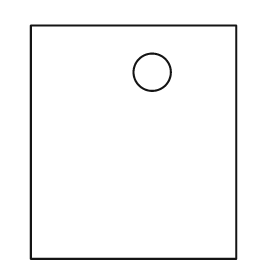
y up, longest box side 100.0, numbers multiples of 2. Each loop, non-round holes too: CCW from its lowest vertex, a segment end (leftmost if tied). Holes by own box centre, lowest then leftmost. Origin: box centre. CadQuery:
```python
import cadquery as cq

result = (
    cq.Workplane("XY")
    .moveTo(-44.0, -50.0)
    .lineTo(44.0, -50.0)
    .lineTo(44.0, 50.0)
    .lineTo(-44.0, 50.0)
    .close()
    .moveTo(8.0, 30.0)
    .circle(8.0)
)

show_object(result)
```